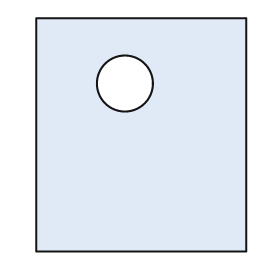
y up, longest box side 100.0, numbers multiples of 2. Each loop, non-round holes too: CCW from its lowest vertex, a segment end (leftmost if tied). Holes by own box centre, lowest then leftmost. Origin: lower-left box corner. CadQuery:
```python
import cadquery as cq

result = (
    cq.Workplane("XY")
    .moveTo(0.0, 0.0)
    .lineTo(90.0, 0.0)
    .lineTo(90.0, 100.0)
    .lineTo(0.0, 100.0)
    .close()
    .moveTo(38.0, 72.0)
    .circle(12.0)
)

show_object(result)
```